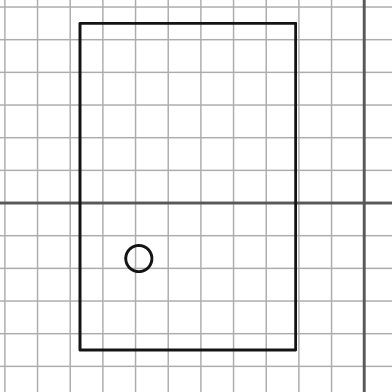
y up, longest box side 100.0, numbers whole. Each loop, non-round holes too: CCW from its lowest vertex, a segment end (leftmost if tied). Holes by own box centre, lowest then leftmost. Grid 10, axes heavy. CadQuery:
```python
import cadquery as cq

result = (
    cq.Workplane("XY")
    .moveTo(-87.0, -45.0)
    .lineTo(-21.0, -45.0)
    .lineTo(-21.0, 55.0)
    .lineTo(-87.0, 55.0)
    .close()
    .moveTo(-69.0, -17.0)
    .circle(4.0)
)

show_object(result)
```